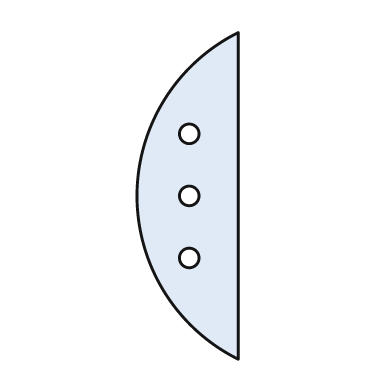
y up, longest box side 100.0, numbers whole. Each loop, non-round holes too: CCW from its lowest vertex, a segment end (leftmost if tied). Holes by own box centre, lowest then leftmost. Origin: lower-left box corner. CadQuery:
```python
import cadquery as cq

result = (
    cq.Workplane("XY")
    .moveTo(31.0, 0.0)
    .lineTo(31.0, 100.0)
    .threePointArc((0.0, 50.0), (31.0, 0.0))
    .close()
    .moveTo(16.0, 31.0)
    .circle(3.0)
    .moveTo(16.0, 50.0)
    .circle(3.0)
    .moveTo(16.0, 69.0)
    .circle(3.0)
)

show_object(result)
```